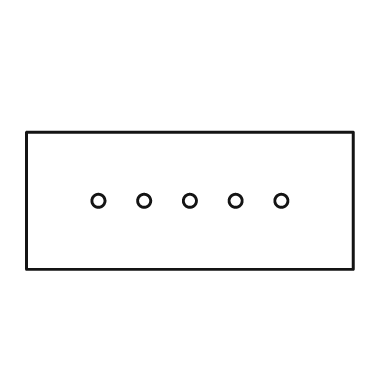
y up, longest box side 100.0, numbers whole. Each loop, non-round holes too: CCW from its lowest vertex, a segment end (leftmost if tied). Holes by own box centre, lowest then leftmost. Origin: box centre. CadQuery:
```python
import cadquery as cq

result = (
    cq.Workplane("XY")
    .moveTo(-50.0, -21.0)
    .lineTo(50.0, -21.0)
    .lineTo(50.0, 21.0)
    .lineTo(-50.0, 21.0)
    .close()
    .moveTo(-28.0, 0.0)
    .circle(2.0)
    .moveTo(-14.0, 0.0)
    .circle(2.0)
    .moveTo(0.0, 0.0)
    .circle(2.0)
    .moveTo(14.0, 0.0)
    .circle(2.0)
    .moveTo(28.0, 0.0)
    .circle(2.0)
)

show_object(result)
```